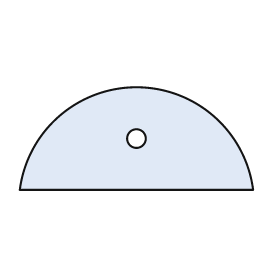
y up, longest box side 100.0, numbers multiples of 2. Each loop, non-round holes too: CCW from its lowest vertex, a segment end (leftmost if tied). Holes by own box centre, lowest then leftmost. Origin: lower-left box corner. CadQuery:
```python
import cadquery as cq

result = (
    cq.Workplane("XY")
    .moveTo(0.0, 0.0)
    .lineTo(100.0, 0.0)
    .threePointArc((50.0, 44.0), (0.0, 0.0))
    .close()
    .moveTo(50.0, 22.0)
    .circle(4.0)
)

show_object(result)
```